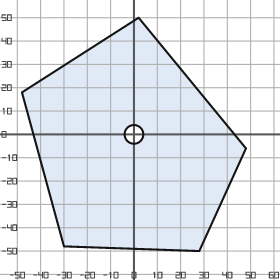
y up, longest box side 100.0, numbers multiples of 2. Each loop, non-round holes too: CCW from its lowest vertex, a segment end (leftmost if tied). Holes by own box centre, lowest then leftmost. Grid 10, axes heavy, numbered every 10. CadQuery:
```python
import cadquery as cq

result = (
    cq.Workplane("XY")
    .moveTo(28.0, -50.0)
    .lineTo(48.0, -6.0)
    .lineTo(2.0, 50.0)
    .lineTo(-48.0, 18.0)
    .lineTo(-30.0, -48.0)
    .close()
    .moveTo(0.0, 0.0)
    .circle(4.0)
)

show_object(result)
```